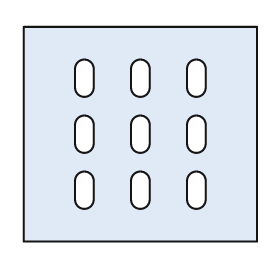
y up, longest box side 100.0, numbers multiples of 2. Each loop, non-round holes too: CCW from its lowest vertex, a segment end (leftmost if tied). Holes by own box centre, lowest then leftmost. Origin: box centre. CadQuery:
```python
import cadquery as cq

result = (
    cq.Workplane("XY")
    .moveTo(-50.0, -46.0)
    .lineTo(50.0, -46.0)
    .lineTo(50.0, 46.0)
    .lineTo(-50.0, 46.0)
    .close()
    .moveTo(-28.0, -28.0)
    .threePointArc((-24.0, -32.0), (-20.0, -28.0))
    .lineTo(-20.0, -20.0)
    .threePointArc((-24.0, -16.0), (-28.0, -20.0))
    .close()
    .moveTo(-4.0, -28.0)
    .threePointArc((0.0, -32.0), (4.0, -28.0))
    .lineTo(4.0, -20.0)
    .threePointArc((0.0, -16.0), (-4.0, -20.0))
    .close()
    .moveTo(20.0, -28.0)
    .threePointArc((24.0, -32.0), (28.0, -28.0))
    .lineTo(28.0, -20.0)
    .threePointArc((24.0, -16.0), (20.0, -20.0))
    .close()
    .moveTo(-28.0, -4.0)
    .threePointArc((-24.0, -8.0), (-20.0, -4.0))
    .lineTo(-20.0, 4.0)
    .threePointArc((-24.0, 8.0), (-28.0, 4.0))
    .close()
    .moveTo(-4.0, -4.0)
    .threePointArc((0.0, -8.0), (4.0, -4.0))
    .lineTo(4.0, 4.0)
    .threePointArc((0.0, 8.0), (-4.0, 4.0))
    .close()
    .moveTo(20.0, -4.0)
    .threePointArc((24.0, -8.0), (28.0, -4.0))
    .lineTo(28.0, 4.0)
    .threePointArc((24.0, 8.0), (20.0, 4.0))
    .close()
    .moveTo(-28.0, 20.0)
    .threePointArc((-24.0, 16.0), (-20.0, 20.0))
    .lineTo(-20.0, 28.0)
    .threePointArc((-24.0, 32.0), (-28.0, 28.0))
    .close()
    .moveTo(-4.0, 20.0)
    .threePointArc((0.0, 16.0), (4.0, 20.0))
    .lineTo(4.0, 28.0)
    .threePointArc((0.0, 32.0), (-4.0, 28.0))
    .close()
    .moveTo(20.0, 20.0)
    .threePointArc((24.0, 16.0), (28.0, 20.0))
    .lineTo(28.0, 28.0)
    .threePointArc((24.0, 32.0), (20.0, 28.0))
    .close()
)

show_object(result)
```